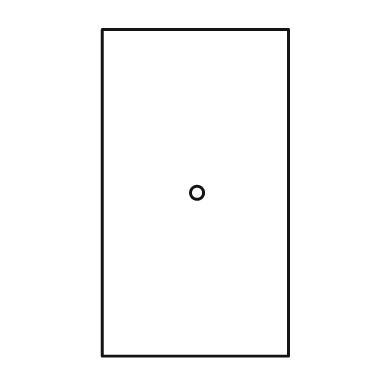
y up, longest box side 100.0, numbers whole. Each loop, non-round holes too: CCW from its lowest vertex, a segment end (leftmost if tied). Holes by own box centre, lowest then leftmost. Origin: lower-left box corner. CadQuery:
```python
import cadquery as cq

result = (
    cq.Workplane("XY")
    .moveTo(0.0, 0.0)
    .lineTo(57.0, 0.0)
    .lineTo(57.0, 100.0)
    .lineTo(0.0, 100.0)
    .close()
    .moveTo(29.0, 50.0)
    .circle(2.0)
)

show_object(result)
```